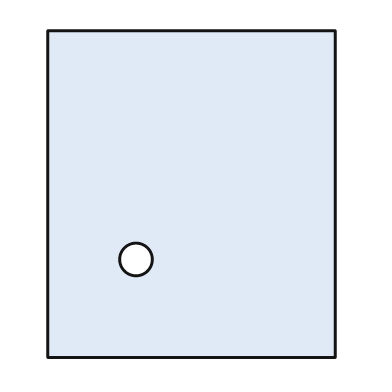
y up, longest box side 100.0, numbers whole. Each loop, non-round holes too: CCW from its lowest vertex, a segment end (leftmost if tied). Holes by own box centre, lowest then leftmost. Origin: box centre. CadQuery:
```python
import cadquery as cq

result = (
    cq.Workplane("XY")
    .moveTo(-44.0, -50.0)
    .lineTo(44.0, -50.0)
    .lineTo(44.0, 50.0)
    .lineTo(-44.0, 50.0)
    .close()
    .moveTo(-17.0, -20.0)
    .circle(5.0)
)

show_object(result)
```